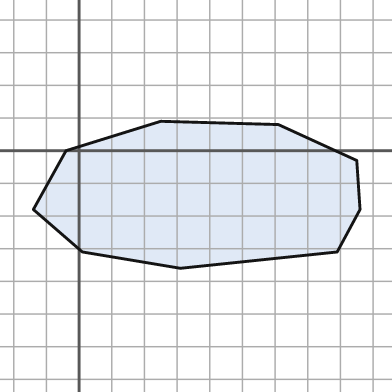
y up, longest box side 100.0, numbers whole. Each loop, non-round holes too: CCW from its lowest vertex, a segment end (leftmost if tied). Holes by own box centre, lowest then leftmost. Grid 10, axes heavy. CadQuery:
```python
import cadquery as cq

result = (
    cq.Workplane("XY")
    .moveTo(31.0, -36.0)
    .lineTo(79.0, -31.0)
    .lineTo(86.0, -18.0)
    .lineTo(85.0, -3.0)
    .lineTo(61.0, 8.0)
    .lineTo(25.0, 9.0)
    .lineTo(-4.0, 0.0)
    .lineTo(-14.0, -18.0)
    .lineTo(1.0, -31.0)
    .close()
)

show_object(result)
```